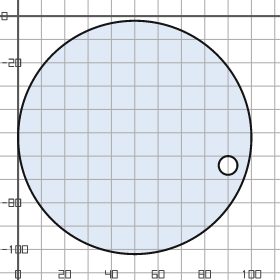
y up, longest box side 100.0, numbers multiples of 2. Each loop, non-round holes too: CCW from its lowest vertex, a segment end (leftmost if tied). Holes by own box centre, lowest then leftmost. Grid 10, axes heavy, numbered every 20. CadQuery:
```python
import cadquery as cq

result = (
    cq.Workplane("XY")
    .moveTo(50.0, -52.0)
    .circle(50.0)
    .moveTo(90.0, -64.0)
    .circle(4.0)
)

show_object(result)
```